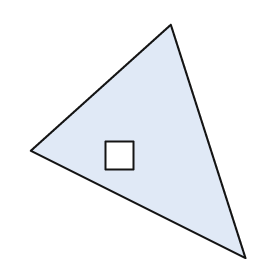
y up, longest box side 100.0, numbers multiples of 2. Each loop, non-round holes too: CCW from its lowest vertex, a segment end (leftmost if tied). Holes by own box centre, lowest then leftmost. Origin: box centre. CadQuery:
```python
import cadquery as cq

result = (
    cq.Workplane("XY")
    .moveTo(46.0, -50.0)
    .lineTo(14.0, 50.0)
    .lineTo(-46.0, -4.0)
    .close()
    .moveTo(-14.0, -12.0)
    .lineTo(-2.0, -12.0)
    .lineTo(-2.0, 0.0)
    .lineTo(-14.0, 0.0)
    .close()
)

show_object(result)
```